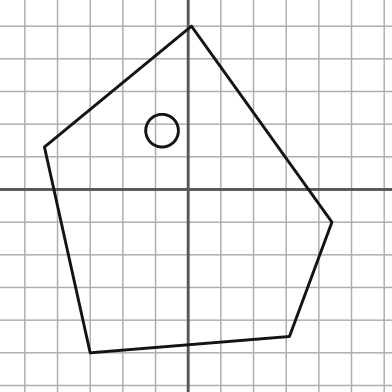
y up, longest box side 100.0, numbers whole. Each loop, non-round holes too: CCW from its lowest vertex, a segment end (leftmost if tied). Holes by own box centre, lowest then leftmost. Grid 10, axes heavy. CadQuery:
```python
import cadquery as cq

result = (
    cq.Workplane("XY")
    .moveTo(-30.0, -50.0)
    .lineTo(31.0, -45.0)
    .lineTo(44.0, -10.0)
    .lineTo(1.0, 50.0)
    .lineTo(-44.0, 13.0)
    .close()
    .moveTo(-8.0, 18.0)
    .circle(5.0)
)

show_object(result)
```